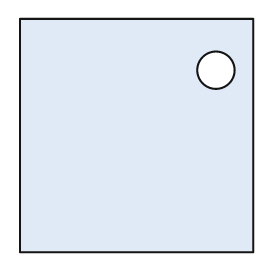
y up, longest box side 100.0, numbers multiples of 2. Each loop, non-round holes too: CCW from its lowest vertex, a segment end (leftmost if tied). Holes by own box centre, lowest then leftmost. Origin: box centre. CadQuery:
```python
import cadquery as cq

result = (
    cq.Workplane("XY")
    .moveTo(-50.0, -50.0)
    .lineTo(50.0, -50.0)
    .lineTo(50.0, 50.0)
    .lineTo(-50.0, 50.0)
    .close()
    .moveTo(34.0, 28.0)
    .circle(8.0)
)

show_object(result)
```